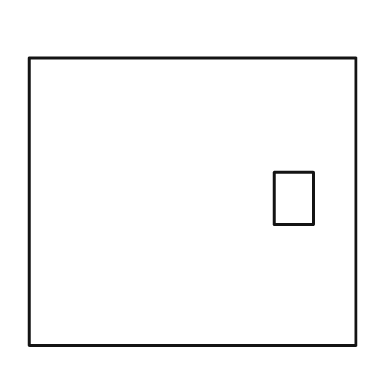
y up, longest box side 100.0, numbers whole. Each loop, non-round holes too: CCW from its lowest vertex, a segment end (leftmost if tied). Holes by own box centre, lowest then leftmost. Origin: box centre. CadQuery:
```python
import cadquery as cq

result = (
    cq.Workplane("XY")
    .moveTo(-50.0, -44.0)
    .lineTo(50.0, -44.0)
    .lineTo(50.0, 44.0)
    .lineTo(-50.0, 44.0)
    .close()
    .moveTo(25.0, -7.0)
    .lineTo(37.0, -7.0)
    .lineTo(37.0, 9.0)
    .lineTo(25.0, 9.0)
    .close()
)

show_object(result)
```